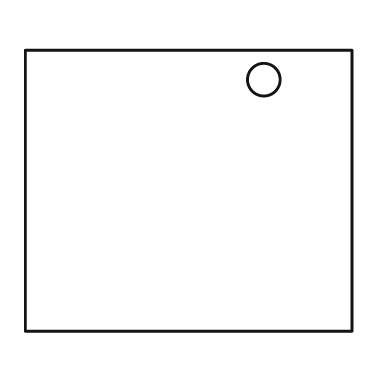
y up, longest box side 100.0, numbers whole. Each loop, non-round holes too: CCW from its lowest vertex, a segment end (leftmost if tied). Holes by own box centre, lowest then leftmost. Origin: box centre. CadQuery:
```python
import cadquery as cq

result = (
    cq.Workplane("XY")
    .moveTo(-50.0, -43.0)
    .lineTo(50.0, -43.0)
    .lineTo(50.0, 43.0)
    .lineTo(-50.0, 43.0)
    .close()
    .moveTo(23.0, 34.0)
    .circle(5.0)
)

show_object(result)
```